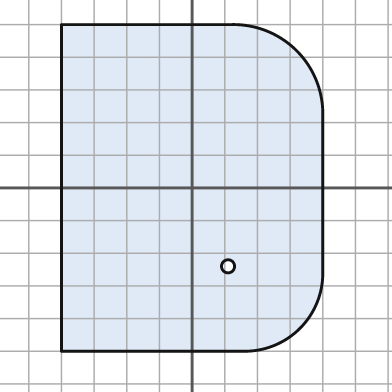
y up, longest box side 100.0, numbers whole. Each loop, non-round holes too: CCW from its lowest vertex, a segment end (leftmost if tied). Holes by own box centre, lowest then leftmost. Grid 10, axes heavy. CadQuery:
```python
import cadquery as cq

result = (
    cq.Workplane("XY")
    .moveTo(-40.0, -50.0)
    .lineTo(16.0, -50.0)
    .threePointArc((33.0, -43.0), (40.0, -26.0))
    .lineTo(40.0, 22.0)
    .threePointArc((32.0, 42.0), (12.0, 50.0))
    .lineTo(-40.0, 50.0)
    .close()
    .moveTo(11.0, -24.0)
    .circle(2.0)
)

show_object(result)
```